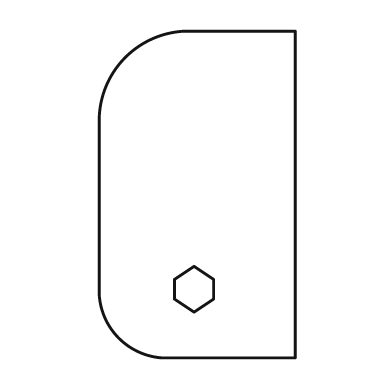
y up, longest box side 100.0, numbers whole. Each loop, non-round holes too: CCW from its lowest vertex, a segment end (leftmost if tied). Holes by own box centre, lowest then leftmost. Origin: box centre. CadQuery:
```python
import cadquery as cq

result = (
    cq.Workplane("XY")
    .moveTo(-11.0, -50.0)
    .lineTo(30.0, -50.0)
    .lineTo(30.0, 50.0)
    .lineTo(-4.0, 50.0)
    .threePointArc((-22.0, 42.0), (-30.0, 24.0))
    .lineTo(-30.0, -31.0)
    .threePointArc((-24.0, -44.0), (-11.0, -50.0))
    .close()
    .moveTo(-1.0, -36.0)
    .lineTo(5.0, -32.0)
    .lineTo(5.0, -26.0)
    .lineTo(-1.0, -22.0)
    .lineTo(-7.0, -26.0)
    .lineTo(-7.0, -32.0)
    .close()
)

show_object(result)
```